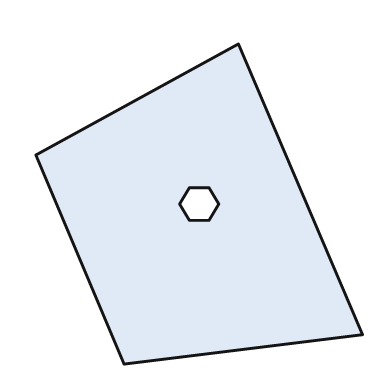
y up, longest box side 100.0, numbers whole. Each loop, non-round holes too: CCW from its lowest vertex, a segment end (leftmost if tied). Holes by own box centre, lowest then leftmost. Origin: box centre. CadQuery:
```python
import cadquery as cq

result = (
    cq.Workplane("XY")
    .moveTo(-23.0, -49.0)
    .lineTo(50.0, -40.0)
    .lineTo(12.0, 49.0)
    .lineTo(-50.0, 15.0)
    .close()
    .moveTo(-3.0, -5.0)
    .lineTo(3.0, -5.0)
    .lineTo(6.0, 0.0)
    .lineTo(3.0, 5.0)
    .lineTo(-3.0, 5.0)
    .lineTo(-6.0, 0.0)
    .close()
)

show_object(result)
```